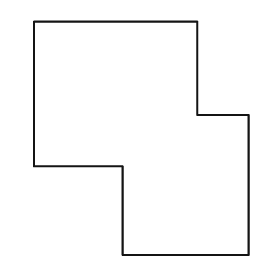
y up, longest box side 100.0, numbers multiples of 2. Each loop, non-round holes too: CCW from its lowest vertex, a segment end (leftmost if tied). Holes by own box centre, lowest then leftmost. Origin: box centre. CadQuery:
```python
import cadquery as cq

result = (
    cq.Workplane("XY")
    .moveTo(-8.0, -50.0)
    .lineTo(46.0, -50.0)
    .lineTo(46.0, 10.0)
    .lineTo(24.0, 10.0)
    .lineTo(24.0, 50.0)
    .lineTo(-46.0, 50.0)
    .lineTo(-46.0, -12.0)
    .lineTo(-8.0, -12.0)
    .close()
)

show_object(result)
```